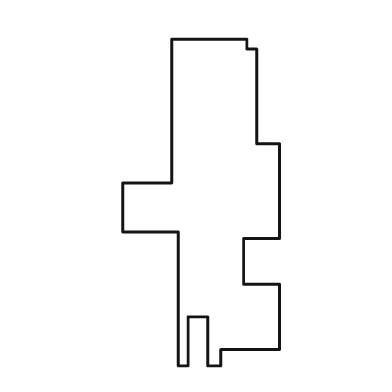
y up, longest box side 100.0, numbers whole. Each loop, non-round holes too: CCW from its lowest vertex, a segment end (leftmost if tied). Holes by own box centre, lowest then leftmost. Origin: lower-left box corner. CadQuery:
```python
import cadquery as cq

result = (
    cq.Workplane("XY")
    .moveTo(17.0, 0.0)
    .lineTo(20.0, 0.0)
    .lineTo(20.0, 15.0)
    .lineTo(26.0, 15.0)
    .lineTo(26.0, 0.0)
    .lineTo(30.0, 0.0)
    .lineTo(30.0, 5.0)
    .lineTo(48.0, 5.0)
    .lineTo(48.0, 25.0)
    .lineTo(37.0, 25.0)
    .lineTo(37.0, 39.0)
    .lineTo(48.0, 39.0)
    .lineTo(48.0, 68.0)
    .lineTo(41.0, 68.0)
    .lineTo(41.0, 97.0)
    .lineTo(38.0, 97.0)
    .lineTo(38.0, 100.0)
    .lineTo(15.0, 100.0)
    .lineTo(15.0, 56.0)
    .lineTo(0.0, 56.0)
    .lineTo(0.0, 41.0)
    .lineTo(17.0, 41.0)
    .close()
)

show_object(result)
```